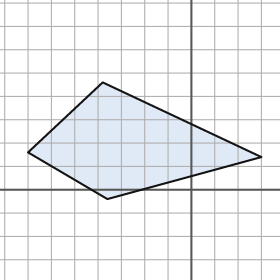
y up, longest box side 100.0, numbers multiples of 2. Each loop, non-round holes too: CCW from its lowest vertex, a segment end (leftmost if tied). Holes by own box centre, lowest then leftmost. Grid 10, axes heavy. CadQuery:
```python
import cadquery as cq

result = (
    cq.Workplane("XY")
    .moveTo(-36.0, -4.0)
    .lineTo(30.0, 14.0)
    .lineTo(-38.0, 46.0)
    .lineTo(-70.0, 16.0)
    .close()
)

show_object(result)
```